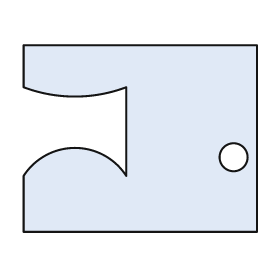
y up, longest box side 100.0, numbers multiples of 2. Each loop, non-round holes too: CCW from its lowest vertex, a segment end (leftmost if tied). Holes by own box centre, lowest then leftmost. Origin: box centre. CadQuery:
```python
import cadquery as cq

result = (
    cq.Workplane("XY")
    .moveTo(-50.0, -40.0)
    .lineTo(50.0, -40.0)
    .lineTo(50.0, 40.0)
    .lineTo(-50.0, 40.0)
    .lineTo(-50.0, 22.0)
    .threePointArc((-28.0, 18.0), (-6.0, 22.0))
    .lineTo(-6.0, -16.0)
    .threePointArc((-28.0, -4.0), (-50.0, -16.0))
    .close()
    .moveTo(40.0, -8.0)
    .circle(6.0)
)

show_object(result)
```